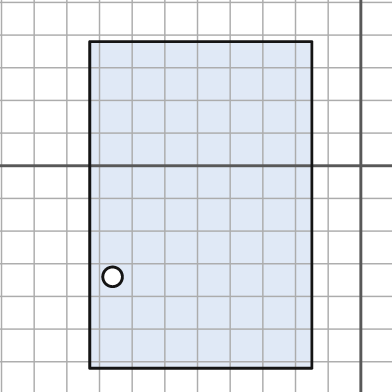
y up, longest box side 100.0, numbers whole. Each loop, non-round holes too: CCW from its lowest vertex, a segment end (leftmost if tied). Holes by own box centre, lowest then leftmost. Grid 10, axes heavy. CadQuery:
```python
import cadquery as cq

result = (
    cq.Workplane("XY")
    .moveTo(-83.0, -62.0)
    .lineTo(-15.0, -62.0)
    .lineTo(-15.0, 38.0)
    .lineTo(-83.0, 38.0)
    .close()
    .moveTo(-76.0, -34.0)
    .circle(3.0)
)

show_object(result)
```